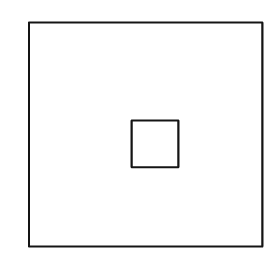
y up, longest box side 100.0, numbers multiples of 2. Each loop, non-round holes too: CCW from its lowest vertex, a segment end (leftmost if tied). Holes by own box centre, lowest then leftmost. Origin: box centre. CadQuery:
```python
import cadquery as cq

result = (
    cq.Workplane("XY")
    .moveTo(-50.0, -48.0)
    .lineTo(50.0, -48.0)
    .lineTo(50.0, 48.0)
    .lineTo(-50.0, 48.0)
    .close()
    .moveTo(-6.0, -14.0)
    .lineTo(14.0, -14.0)
    .lineTo(14.0, 6.0)
    .lineTo(-6.0, 6.0)
    .close()
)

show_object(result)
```